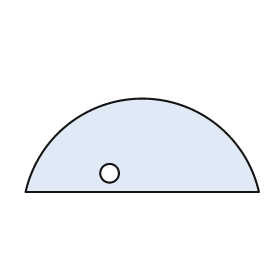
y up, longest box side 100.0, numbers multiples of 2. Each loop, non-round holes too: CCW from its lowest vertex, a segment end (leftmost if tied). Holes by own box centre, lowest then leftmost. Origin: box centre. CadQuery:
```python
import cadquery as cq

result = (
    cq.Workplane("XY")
    .moveTo(-50.0, -20.0)
    .lineTo(50.0, -20.0)
    .threePointArc((0.0, 20.0), (-50.0, -20.0))
    .close()
    .moveTo(-14.0, -12.0)
    .circle(4.0)
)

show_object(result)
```